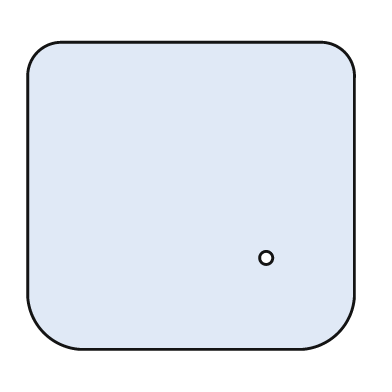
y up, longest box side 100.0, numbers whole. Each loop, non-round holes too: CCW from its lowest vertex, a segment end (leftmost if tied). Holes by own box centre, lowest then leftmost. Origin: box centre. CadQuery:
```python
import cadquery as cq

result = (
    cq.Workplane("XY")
    .moveTo(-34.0, -47.0)
    .lineTo(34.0, -47.0)
    .threePointArc((45.0, -42.0), (50.0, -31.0))
    .lineTo(50.0, 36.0)
    .threePointArc((47.0, 44.0), (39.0, 47.0))
    .lineTo(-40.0, 47.0)
    .threePointArc((-47.0, 44.0), (-50.0, 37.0))
    .lineTo(-50.0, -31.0)
    .threePointArc((-45.0, -42.0), (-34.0, -47.0))
    .close()
    .moveTo(23.0, -19.0)
    .circle(2.0)
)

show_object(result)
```